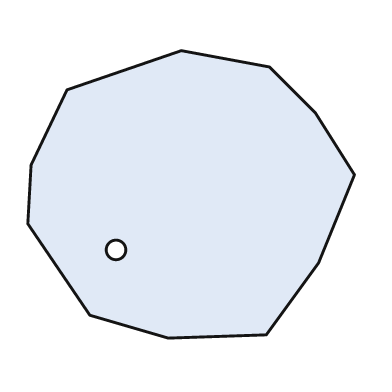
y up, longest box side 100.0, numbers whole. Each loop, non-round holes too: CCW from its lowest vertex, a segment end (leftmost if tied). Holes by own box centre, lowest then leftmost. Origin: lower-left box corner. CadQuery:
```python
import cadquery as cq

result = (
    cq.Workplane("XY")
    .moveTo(43.0, 0.0)
    .lineTo(73.0, 1.0)
    .lineTo(89.0, 23.0)
    .lineTo(100.0, 50.0)
    .lineTo(88.0, 69.0)
    .lineTo(74.0, 83.0)
    .lineTo(47.0, 88.0)
    .lineTo(12.0, 76.0)
    .lineTo(1.0, 53.0)
    .lineTo(0.0, 35.0)
    .lineTo(19.0, 7.0)
    .close()
    .moveTo(27.0, 27.0)
    .circle(3.0)
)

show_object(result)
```